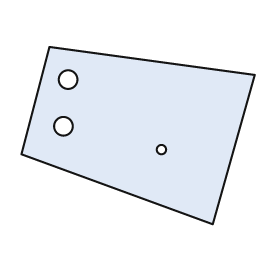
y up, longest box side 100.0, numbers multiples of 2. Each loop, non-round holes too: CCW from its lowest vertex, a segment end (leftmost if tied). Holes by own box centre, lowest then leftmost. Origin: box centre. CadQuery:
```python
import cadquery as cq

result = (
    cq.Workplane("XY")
    .moveTo(32.0, -38.0)
    .lineTo(50.0, 26.0)
    .lineTo(-38.0, 38.0)
    .lineTo(-50.0, -8.0)
    .close()
    .moveTo(10.0, -6.0)
    .circle(2.0)
    .moveTo(-32.0, 4.0)
    .circle(4.0)
    .moveTo(-30.0, 24.0)
    .circle(4.0)
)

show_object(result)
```